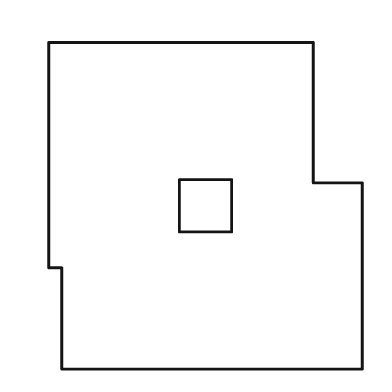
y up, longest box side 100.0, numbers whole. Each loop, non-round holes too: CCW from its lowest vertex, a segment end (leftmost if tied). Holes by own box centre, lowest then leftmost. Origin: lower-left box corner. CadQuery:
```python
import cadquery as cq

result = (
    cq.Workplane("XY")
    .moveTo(4.0, 0.0)
    .lineTo(96.0, 0.0)
    .lineTo(96.0, 57.0)
    .lineTo(81.0, 57.0)
    .lineTo(81.0, 100.0)
    .lineTo(0.0, 100.0)
    .lineTo(0.0, 31.0)
    .lineTo(4.0, 31.0)
    .close()
    .moveTo(40.0, 42.0)
    .lineTo(56.0, 42.0)
    .lineTo(56.0, 58.0)
    .lineTo(40.0, 58.0)
    .close()
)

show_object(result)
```